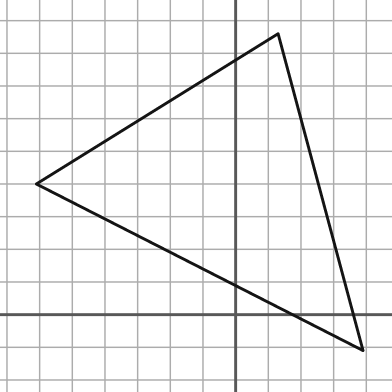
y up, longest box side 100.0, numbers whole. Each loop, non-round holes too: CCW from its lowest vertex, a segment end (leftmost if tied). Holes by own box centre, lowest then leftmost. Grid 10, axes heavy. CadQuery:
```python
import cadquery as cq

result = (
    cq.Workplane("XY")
    .moveTo(39.0, -11.0)
    .lineTo(13.0, 86.0)
    .lineTo(-61.0, 40.0)
    .close()
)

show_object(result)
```